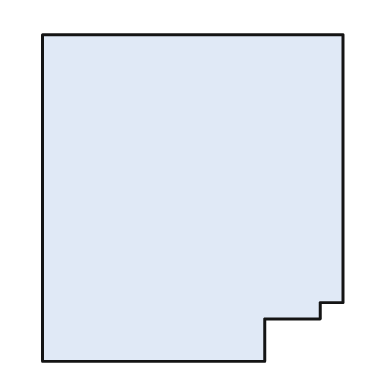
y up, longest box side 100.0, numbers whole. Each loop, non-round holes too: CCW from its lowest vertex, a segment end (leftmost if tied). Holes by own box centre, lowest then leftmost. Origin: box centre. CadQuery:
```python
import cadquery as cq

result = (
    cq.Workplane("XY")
    .moveTo(-46.0, -50.0)
    .lineTo(22.0, -50.0)
    .lineTo(22.0, -37.0)
    .lineTo(39.0, -37.0)
    .lineTo(39.0, -32.0)
    .lineTo(46.0, -32.0)
    .lineTo(46.0, 50.0)
    .lineTo(-46.0, 50.0)
    .close()
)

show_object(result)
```